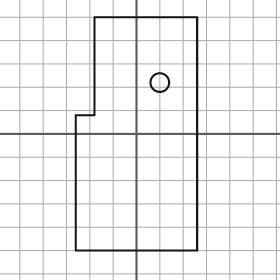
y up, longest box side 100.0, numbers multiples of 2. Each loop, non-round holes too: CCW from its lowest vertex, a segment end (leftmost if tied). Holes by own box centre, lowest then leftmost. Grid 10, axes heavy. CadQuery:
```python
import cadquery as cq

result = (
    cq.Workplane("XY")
    .moveTo(-26.0, -50.0)
    .lineTo(26.0, -50.0)
    .lineTo(26.0, 50.0)
    .lineTo(-18.0, 50.0)
    .lineTo(-18.0, 8.0)
    .lineTo(-26.0, 8.0)
    .close()
    .moveTo(10.0, 22.0)
    .circle(4.0)
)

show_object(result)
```